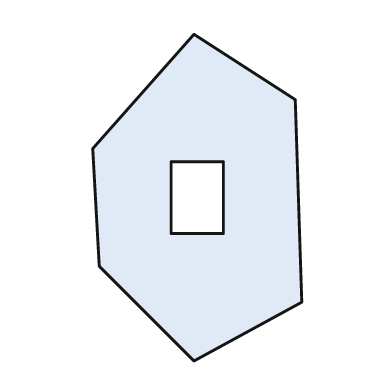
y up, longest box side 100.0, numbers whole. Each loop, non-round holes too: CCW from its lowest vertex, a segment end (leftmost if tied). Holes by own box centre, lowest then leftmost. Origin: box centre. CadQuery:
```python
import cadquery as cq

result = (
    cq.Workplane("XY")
    .moveTo(-1.0, -50.0)
    .lineTo(32.0, -32.0)
    .lineTo(30.0, 30.0)
    .lineTo(-1.0, 50.0)
    .lineTo(-32.0, 15.0)
    .lineTo(-30.0, -21.0)
    .close()
    .moveTo(-8.0, -11.0)
    .lineTo(8.0, -11.0)
    .lineTo(8.0, 11.0)
    .lineTo(-8.0, 11.0)
    .close()
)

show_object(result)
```